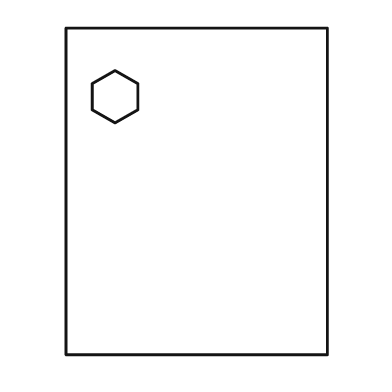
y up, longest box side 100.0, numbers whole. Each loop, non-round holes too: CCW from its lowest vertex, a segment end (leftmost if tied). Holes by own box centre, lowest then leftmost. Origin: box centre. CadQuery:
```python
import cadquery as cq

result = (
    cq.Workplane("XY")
    .moveTo(-40.0, -50.0)
    .lineTo(40.0, -50.0)
    .lineTo(40.0, 50.0)
    .lineTo(-40.0, 50.0)
    .close()
    .moveTo(-25.0, 21.0)
    .lineTo(-18.0, 25.0)
    .lineTo(-18.0, 33.0)
    .lineTo(-25.0, 37.0)
    .lineTo(-32.0, 33.0)
    .lineTo(-32.0, 25.0)
    .close()
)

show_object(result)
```